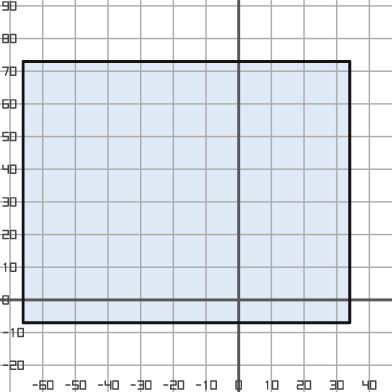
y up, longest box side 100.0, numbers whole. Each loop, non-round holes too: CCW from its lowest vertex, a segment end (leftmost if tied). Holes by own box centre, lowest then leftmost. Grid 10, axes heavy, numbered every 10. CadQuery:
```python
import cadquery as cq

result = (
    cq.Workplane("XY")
    .moveTo(-66.0, -7.0)
    .lineTo(34.0, -7.0)
    .lineTo(34.0, 73.0)
    .lineTo(-66.0, 73.0)
    .close()
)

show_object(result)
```